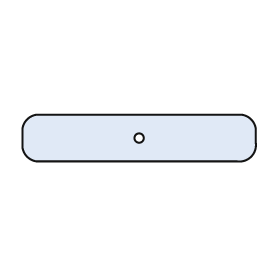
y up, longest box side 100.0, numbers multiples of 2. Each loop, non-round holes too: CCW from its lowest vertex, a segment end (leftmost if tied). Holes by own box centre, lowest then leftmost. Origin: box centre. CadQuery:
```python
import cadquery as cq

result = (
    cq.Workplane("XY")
    .moveTo(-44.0, -10.0)
    .lineTo(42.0, -10.0)
    .threePointArc((48.0, -8.0), (50.0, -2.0))
    .lineTo(50.0, 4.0)
    .threePointArc((48.0, 8.0), (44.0, 10.0))
    .lineTo(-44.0, 10.0)
    .threePointArc((-48.0, 8.0), (-50.0, 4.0))
    .lineTo(-50.0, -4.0)
    .threePointArc((-48.0, -8.0), (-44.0, -10.0))
    .close()
    .moveTo(0.0, 0.0)
    .circle(2.0)
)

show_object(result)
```